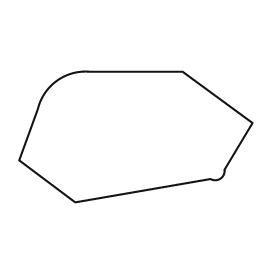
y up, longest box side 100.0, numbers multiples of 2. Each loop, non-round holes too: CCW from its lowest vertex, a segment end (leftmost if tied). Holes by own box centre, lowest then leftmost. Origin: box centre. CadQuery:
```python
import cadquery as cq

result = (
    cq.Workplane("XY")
    .moveTo(-26.0, -28.0)
    .lineTo(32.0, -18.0)
    .threePointArc((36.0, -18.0), (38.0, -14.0))
    .lineTo(50.0, 6.0)
    .lineTo(20.0, 28.0)
    .lineTo(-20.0, 28.0)
    .threePointArc((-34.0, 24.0), (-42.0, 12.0))
    .lineTo(-50.0, -10.0)
    .close()
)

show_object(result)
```